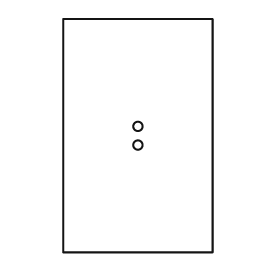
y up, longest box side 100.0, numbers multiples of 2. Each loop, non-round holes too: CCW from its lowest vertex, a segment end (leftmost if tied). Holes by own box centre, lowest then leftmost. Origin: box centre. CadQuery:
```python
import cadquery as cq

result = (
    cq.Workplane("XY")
    .moveTo(-32.0, -50.0)
    .lineTo(32.0, -50.0)
    .lineTo(32.0, 50.0)
    .lineTo(-32.0, 50.0)
    .close()
    .moveTo(0.0, -4.0)
    .circle(2.0)
    .moveTo(0.0, 4.0)
    .circle(2.0)
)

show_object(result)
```